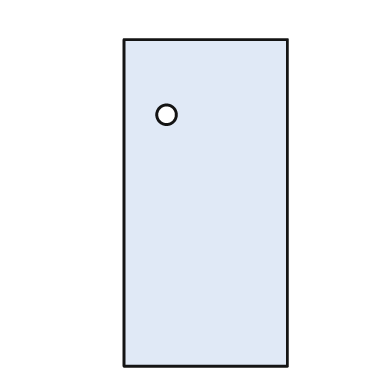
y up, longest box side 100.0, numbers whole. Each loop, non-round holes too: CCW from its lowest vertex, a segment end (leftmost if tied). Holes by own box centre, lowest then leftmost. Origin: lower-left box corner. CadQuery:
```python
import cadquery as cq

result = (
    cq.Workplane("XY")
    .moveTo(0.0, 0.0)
    .lineTo(50.0, 0.0)
    .lineTo(50.0, 100.0)
    .lineTo(0.0, 100.0)
    .close()
    .moveTo(13.0, 77.0)
    .circle(3.0)
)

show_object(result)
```